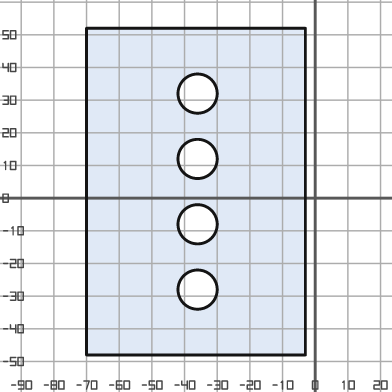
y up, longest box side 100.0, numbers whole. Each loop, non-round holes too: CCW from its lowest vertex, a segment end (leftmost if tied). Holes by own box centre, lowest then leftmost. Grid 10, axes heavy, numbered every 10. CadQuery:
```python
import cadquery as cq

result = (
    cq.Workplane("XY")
    .moveTo(-70.0, -48.0)
    .lineTo(-3.0, -48.0)
    .lineTo(-3.0, 52.0)
    .lineTo(-70.0, 52.0)
    .close()
    .moveTo(-36.0, -28.0)
    .circle(6.0)
    .moveTo(-36.0, -8.0)
    .circle(6.0)
    .moveTo(-36.0, 12.0)
    .circle(6.0)
    .moveTo(-36.0, 32.0)
    .circle(6.0)
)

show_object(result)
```